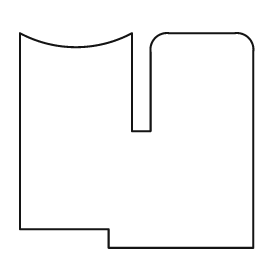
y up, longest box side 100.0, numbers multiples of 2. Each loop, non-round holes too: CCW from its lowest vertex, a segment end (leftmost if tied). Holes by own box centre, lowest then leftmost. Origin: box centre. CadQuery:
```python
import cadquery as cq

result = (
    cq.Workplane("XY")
    .moveTo(-12.0, -46.0)
    .lineTo(50.0, -46.0)
    .lineTo(50.0, 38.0)
    .threePointArc((48.0, 44.0), (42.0, 46.0))
    .lineTo(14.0, 46.0)
    .threePointArc((8.0, 44.0), (6.0, 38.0))
    .lineTo(6.0, 4.0)
    .lineTo(-2.0, 4.0)
    .lineTo(-2.0, 46.0)
    .threePointArc((-26.0, 40.0), (-50.0, 46.0))
    .lineTo(-50.0, -38.0)
    .lineTo(-12.0, -38.0)
    .close()
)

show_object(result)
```